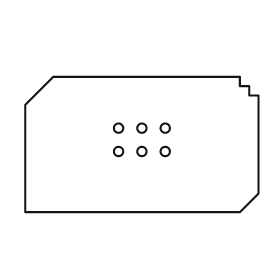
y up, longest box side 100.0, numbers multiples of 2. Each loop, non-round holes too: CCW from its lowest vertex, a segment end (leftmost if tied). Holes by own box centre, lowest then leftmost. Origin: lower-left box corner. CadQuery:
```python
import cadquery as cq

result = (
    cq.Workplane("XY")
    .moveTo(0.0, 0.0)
    .lineTo(92.0, 0.0)
    .lineTo(100.0, 8.0)
    .lineTo(100.0, 50.0)
    .lineTo(96.0, 50.0)
    .lineTo(96.0, 54.0)
    .lineTo(92.0, 54.0)
    .lineTo(92.0, 58.0)
    .lineTo(12.0, 58.0)
    .lineTo(0.0, 46.0)
    .close()
    .moveTo(40.0, 26.0)
    .circle(2.0)
    .moveTo(50.0, 26.0)
    .circle(2.0)
    .moveTo(60.0, 26.0)
    .circle(2.0)
    .moveTo(40.0, 36.0)
    .circle(2.0)
    .moveTo(50.0, 36.0)
    .circle(2.0)
    .moveTo(60.0, 36.0)
    .circle(2.0)
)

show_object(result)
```